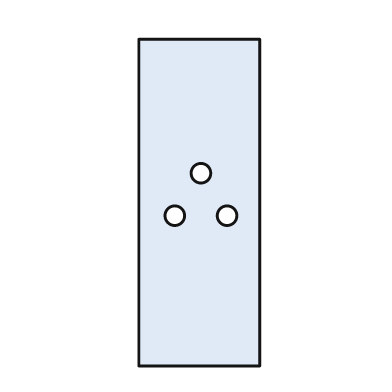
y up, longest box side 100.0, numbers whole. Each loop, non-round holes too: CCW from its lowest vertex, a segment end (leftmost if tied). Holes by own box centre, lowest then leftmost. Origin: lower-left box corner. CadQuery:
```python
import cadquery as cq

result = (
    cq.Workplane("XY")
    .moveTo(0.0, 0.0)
    .lineTo(37.0, 0.0)
    .lineTo(37.0, 100.0)
    .lineTo(0.0, 100.0)
    .close()
    .moveTo(11.0, 46.0)
    .circle(3.0)
    .moveTo(27.0, 46.0)
    .circle(3.0)
    .moveTo(19.0, 59.0)
    .circle(3.0)
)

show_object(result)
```